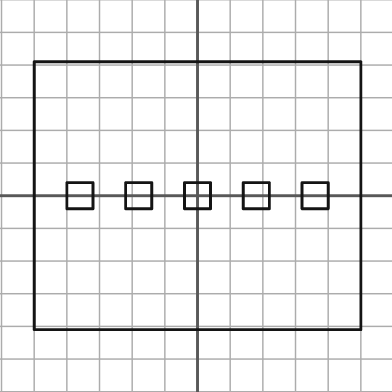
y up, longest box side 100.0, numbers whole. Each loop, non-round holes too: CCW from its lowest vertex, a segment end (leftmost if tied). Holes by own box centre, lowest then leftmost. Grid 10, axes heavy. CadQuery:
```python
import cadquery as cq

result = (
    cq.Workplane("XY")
    .moveTo(-50.0, -41.0)
    .lineTo(50.0, -41.0)
    .lineTo(50.0, 41.0)
    .lineTo(-50.0, 41.0)
    .close()
    .moveTo(-40.0, -4.0)
    .lineTo(-32.0, -4.0)
    .lineTo(-32.0, 4.0)
    .lineTo(-40.0, 4.0)
    .close()
    .moveTo(-22.0, -4.0)
    .lineTo(-14.0, -4.0)
    .lineTo(-14.0, 4.0)
    .lineTo(-22.0, 4.0)
    .close()
    .moveTo(-4.0, -4.0)
    .lineTo(4.0, -4.0)
    .lineTo(4.0, 4.0)
    .lineTo(-4.0, 4.0)
    .close()
    .moveTo(14.0, -4.0)
    .lineTo(22.0, -4.0)
    .lineTo(22.0, 4.0)
    .lineTo(14.0, 4.0)
    .close()
    .moveTo(32.0, -4.0)
    .lineTo(40.0, -4.0)
    .lineTo(40.0, 4.0)
    .lineTo(32.0, 4.0)
    .close()
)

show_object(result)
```